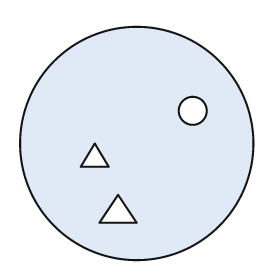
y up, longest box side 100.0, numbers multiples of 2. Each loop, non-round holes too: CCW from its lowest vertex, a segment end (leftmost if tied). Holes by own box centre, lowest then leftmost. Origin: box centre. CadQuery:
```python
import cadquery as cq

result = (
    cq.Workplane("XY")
    .moveTo(0.0, 0.0)
    .circle(50.0)
    .moveTo(-16.0, -34.0)
    .lineTo(0.0, -34.0)
    .lineTo(-8.0, -22.0)
    .close()
    .moveTo(-24.0, -10.0)
    .lineTo(-12.0, -10.0)
    .lineTo(-18.0, 0.0)
    .close()
    .moveTo(24.0, 14.0)
    .circle(6.0)
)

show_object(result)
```